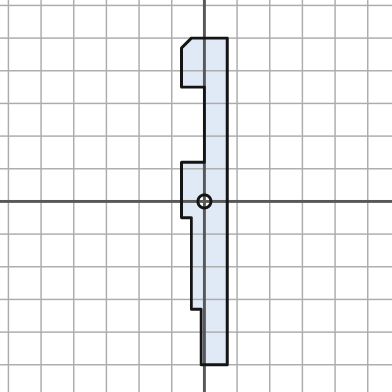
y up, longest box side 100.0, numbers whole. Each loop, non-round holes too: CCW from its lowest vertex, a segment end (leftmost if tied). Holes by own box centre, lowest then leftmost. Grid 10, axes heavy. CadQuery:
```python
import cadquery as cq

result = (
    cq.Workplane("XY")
    .moveTo(-1.0, -50.0)
    .lineTo(7.0, -50.0)
    .lineTo(7.0, 50.0)
    .lineTo(-4.0, 50.0)
    .lineTo(-7.0, 47.0)
    .lineTo(-7.0, 35.0)
    .lineTo(0.0, 35.0)
    .lineTo(0.0, 12.0)
    .lineTo(-7.0, 12.0)
    .lineTo(-7.0, -5.0)
    .lineTo(-4.0, -5.0)
    .lineTo(-4.0, -33.0)
    .lineTo(-1.0, -33.0)
    .close()
    .moveTo(0.0, 0.0)
    .circle(2.0)
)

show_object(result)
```